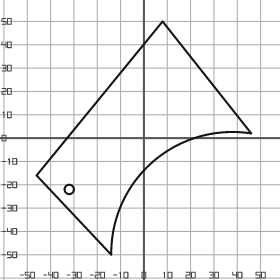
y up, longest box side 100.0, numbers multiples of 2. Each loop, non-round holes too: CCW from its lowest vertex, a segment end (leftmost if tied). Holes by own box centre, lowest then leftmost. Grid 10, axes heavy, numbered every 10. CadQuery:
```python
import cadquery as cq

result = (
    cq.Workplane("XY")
    .moveTo(-14.0, -50.0)
    .threePointArc((4.0, -10.0), (46.0, 2.0))
    .lineTo(8.0, 50.0)
    .lineTo(-46.0, -16.0)
    .close()
    .moveTo(-32.0, -22.0)
    .circle(2.0)
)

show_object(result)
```